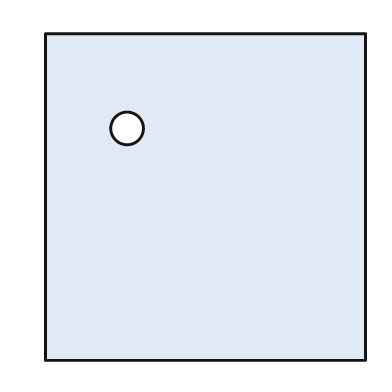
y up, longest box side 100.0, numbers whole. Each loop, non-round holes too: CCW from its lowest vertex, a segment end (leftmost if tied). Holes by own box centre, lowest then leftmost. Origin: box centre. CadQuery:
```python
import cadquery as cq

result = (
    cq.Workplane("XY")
    .moveTo(-49.0, -50.0)
    .lineTo(49.0, -50.0)
    .lineTo(49.0, 50.0)
    .lineTo(-49.0, 50.0)
    .close()
    .moveTo(-24.0, 21.0)
    .circle(5.0)
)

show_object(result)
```